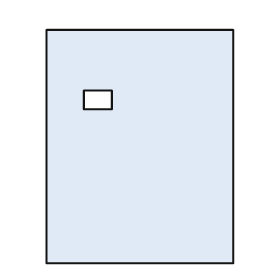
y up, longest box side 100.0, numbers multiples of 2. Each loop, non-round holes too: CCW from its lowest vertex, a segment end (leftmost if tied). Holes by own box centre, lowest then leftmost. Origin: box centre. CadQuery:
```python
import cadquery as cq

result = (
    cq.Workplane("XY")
    .moveTo(-40.0, -50.0)
    .lineTo(40.0, -50.0)
    .lineTo(40.0, 50.0)
    .lineTo(-40.0, 50.0)
    .close()
    .moveTo(-24.0, 16.0)
    .lineTo(-12.0, 16.0)
    .lineTo(-12.0, 24.0)
    .lineTo(-24.0, 24.0)
    .close()
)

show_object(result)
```